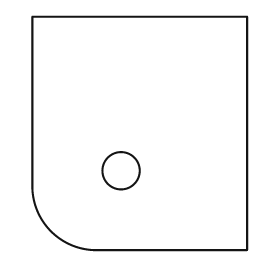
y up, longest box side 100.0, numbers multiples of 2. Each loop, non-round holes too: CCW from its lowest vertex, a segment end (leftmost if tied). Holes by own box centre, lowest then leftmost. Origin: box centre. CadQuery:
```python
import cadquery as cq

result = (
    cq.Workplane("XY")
    .moveTo(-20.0, -50.0)
    .lineTo(46.0, -50.0)
    .lineTo(46.0, 50.0)
    .lineTo(-46.0, 50.0)
    .lineTo(-46.0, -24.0)
    .threePointArc((-38.0, -42.0), (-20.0, -50.0))
    .close()
    .moveTo(-8.0, -16.0)
    .circle(8.0)
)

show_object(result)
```